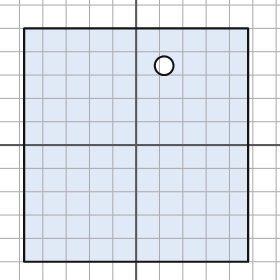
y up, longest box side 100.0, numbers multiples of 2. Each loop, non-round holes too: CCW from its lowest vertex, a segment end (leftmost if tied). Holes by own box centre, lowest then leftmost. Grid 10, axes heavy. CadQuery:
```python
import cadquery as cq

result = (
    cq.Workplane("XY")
    .moveTo(-48.0, -50.0)
    .lineTo(48.0, -50.0)
    .lineTo(48.0, 50.0)
    .lineTo(-48.0, 50.0)
    .close()
    .moveTo(12.0, 34.0)
    .circle(4.0)
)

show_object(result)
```